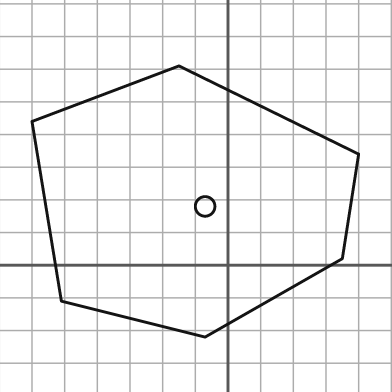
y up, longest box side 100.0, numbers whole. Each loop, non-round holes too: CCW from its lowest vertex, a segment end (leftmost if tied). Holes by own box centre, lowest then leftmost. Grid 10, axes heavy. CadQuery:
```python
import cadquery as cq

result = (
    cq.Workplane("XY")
    .moveTo(-7.0, -22.0)
    .lineTo(35.0, 2.0)
    .lineTo(40.0, 34.0)
    .lineTo(-15.0, 61.0)
    .lineTo(-60.0, 44.0)
    .lineTo(-51.0, -11.0)
    .close()
    .moveTo(-7.0, 18.0)
    .circle(3.0)
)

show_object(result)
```